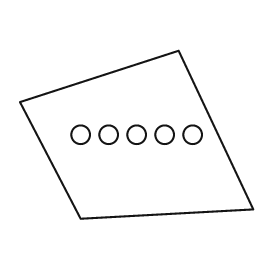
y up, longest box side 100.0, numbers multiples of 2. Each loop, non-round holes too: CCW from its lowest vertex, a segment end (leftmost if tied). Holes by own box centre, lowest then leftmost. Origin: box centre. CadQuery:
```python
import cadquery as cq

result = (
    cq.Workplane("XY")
    .moveTo(-24.0, -36.0)
    .lineTo(50.0, -32.0)
    .lineTo(18.0, 36.0)
    .lineTo(-50.0, 14.0)
    .close()
    .moveTo(-24.0, 0.0)
    .circle(4.0)
    .moveTo(-12.0, 0.0)
    .circle(4.0)
    .moveTo(0.0, 0.0)
    .circle(4.0)
    .moveTo(12.0, 0.0)
    .circle(4.0)
    .moveTo(24.0, 0.0)
    .circle(4.0)
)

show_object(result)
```